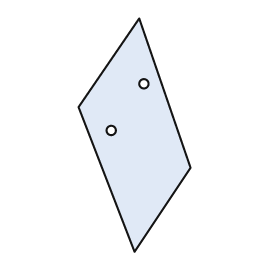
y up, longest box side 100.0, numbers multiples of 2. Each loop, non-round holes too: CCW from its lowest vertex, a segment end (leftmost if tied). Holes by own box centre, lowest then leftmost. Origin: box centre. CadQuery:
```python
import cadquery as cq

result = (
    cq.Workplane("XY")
    .moveTo(0.0, -50.0)
    .lineTo(24.0, -14.0)
    .lineTo(2.0, 50.0)
    .lineTo(-24.0, 12.0)
    .close()
    .moveTo(-10.0, 2.0)
    .circle(2.0)
    .moveTo(4.0, 22.0)
    .circle(2.0)
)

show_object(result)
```